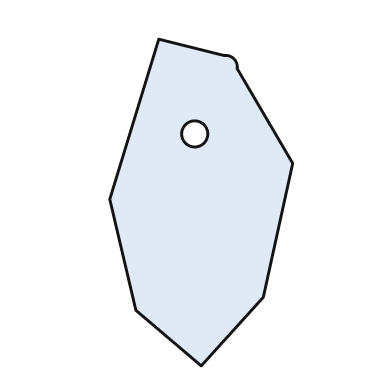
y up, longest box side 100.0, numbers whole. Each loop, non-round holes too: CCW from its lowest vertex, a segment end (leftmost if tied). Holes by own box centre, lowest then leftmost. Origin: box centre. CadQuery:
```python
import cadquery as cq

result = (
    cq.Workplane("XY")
    .moveTo(0.0, -50.0)
    .lineTo(19.0, -29.0)
    .lineTo(28.0, 12.0)
    .lineTo(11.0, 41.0)
    .threePointArc((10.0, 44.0), (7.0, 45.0))
    .lineTo(-13.0, 50.0)
    .lineTo(-28.0, 1.0)
    .lineTo(-20.0, -33.0)
    .close()
    .moveTo(-2.0, 21.0)
    .circle(4.0)
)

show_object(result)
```